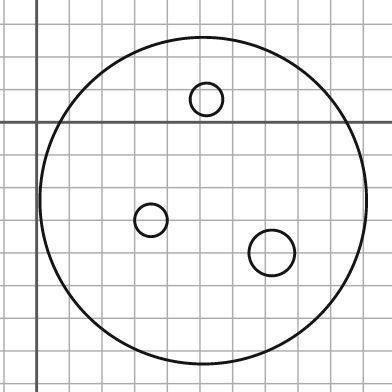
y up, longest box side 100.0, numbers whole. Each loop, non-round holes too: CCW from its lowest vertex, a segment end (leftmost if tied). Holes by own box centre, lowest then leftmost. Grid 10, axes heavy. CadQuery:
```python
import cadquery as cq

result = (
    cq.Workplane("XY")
    .moveTo(51.0, -24.0)
    .circle(50.0)
    .moveTo(72.0, -40.0)
    .circle(7.0)
    .moveTo(35.0, -30.0)
    .circle(5.0)
    .moveTo(52.0, 7.0)
    .circle(5.0)
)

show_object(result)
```